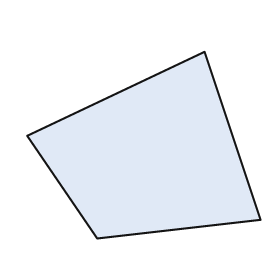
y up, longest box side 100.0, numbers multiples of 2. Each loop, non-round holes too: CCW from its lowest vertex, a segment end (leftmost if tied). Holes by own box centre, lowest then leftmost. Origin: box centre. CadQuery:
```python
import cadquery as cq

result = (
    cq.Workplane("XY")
    .moveTo(-20.0, -40.0)
    .lineTo(50.0, -32.0)
    .lineTo(26.0, 40.0)
    .lineTo(-50.0, 4.0)
    .close()
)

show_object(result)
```